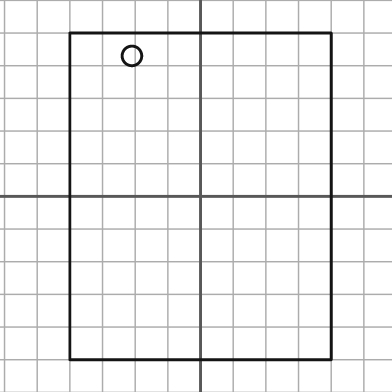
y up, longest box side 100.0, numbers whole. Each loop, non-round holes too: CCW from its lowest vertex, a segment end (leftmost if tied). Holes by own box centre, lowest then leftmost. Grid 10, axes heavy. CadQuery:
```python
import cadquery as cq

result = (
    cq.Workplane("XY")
    .moveTo(-40.0, -50.0)
    .lineTo(40.0, -50.0)
    .lineTo(40.0, 50.0)
    .lineTo(-40.0, 50.0)
    .close()
    .moveTo(-21.0, 43.0)
    .circle(3.0)
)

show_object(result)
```